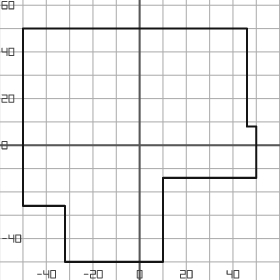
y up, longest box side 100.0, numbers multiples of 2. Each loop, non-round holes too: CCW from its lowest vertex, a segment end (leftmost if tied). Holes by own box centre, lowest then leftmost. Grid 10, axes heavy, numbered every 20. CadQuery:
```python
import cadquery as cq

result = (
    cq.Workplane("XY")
    .moveTo(-32.0, -50.0)
    .lineTo(10.0, -50.0)
    .lineTo(10.0, -14.0)
    .lineTo(50.0, -14.0)
    .lineTo(50.0, 8.0)
    .lineTo(46.0, 8.0)
    .lineTo(46.0, 50.0)
    .lineTo(-50.0, 50.0)
    .lineTo(-50.0, -26.0)
    .lineTo(-32.0, -26.0)
    .close()
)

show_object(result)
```